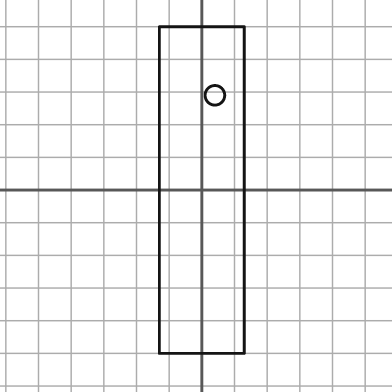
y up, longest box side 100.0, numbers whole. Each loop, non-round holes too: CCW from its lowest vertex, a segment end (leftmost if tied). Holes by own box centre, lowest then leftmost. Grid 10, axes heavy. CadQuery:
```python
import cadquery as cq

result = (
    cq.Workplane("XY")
    .moveTo(-13.0, -50.0)
    .lineTo(13.0, -50.0)
    .lineTo(13.0, 50.0)
    .lineTo(-13.0, 50.0)
    .close()
    .moveTo(4.0, 29.0)
    .circle(3.0)
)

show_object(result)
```